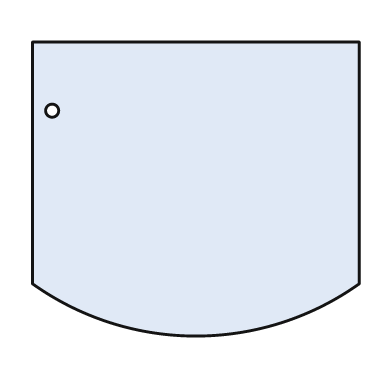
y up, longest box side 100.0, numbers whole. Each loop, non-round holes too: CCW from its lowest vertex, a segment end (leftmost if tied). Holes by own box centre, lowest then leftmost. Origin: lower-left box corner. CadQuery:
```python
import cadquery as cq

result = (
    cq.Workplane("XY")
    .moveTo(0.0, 16.0)
    .threePointArc((50.0, 0.0), (100.0, 16.0))
    .lineTo(100.0, 90.0)
    .lineTo(0.0, 90.0)
    .close()
    .moveTo(6.0, 69.0)
    .circle(2.0)
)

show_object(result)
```